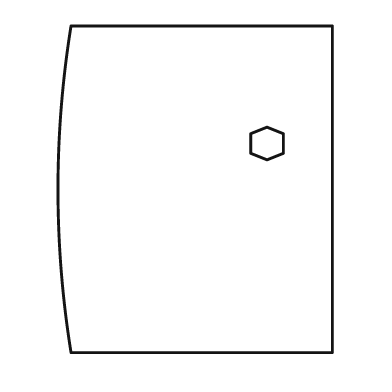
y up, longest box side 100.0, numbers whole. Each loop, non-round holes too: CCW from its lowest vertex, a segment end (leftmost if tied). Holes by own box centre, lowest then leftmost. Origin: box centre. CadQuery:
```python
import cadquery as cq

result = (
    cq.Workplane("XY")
    .moveTo(-38.0, -50.0)
    .lineTo(42.0, -50.0)
    .lineTo(42.0, 50.0)
    .lineTo(-38.0, 50.0)
    .threePointArc((-42.0, 0.0), (-38.0, -50.0))
    .close()
    .moveTo(22.0, 9.0)
    .lineTo(27.0, 11.0)
    .lineTo(27.0, 17.0)
    .lineTo(22.0, 19.0)
    .lineTo(17.0, 17.0)
    .lineTo(17.0, 11.0)
    .close()
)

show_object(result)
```